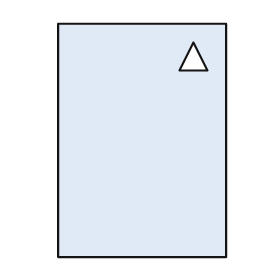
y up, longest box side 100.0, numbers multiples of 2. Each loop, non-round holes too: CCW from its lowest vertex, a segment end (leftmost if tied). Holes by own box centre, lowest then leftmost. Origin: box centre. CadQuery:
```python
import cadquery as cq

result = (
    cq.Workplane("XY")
    .moveTo(-36.0, -50.0)
    .lineTo(36.0, -50.0)
    .lineTo(36.0, 50.0)
    .lineTo(-36.0, 50.0)
    .close()
    .moveTo(16.0, 30.0)
    .lineTo(28.0, 30.0)
    .lineTo(22.0, 42.0)
    .close()
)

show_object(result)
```